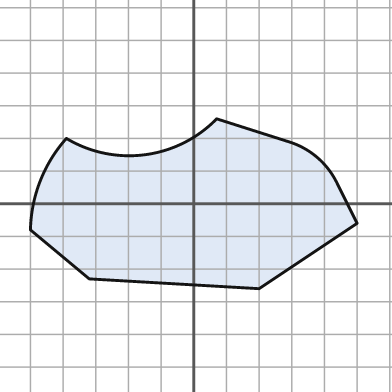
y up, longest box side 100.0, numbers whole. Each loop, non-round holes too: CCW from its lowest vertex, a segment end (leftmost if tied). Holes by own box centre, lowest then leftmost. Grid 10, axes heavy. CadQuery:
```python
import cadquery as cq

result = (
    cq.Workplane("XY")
    .moveTo(20.0, -26.0)
    .lineTo(50.0, -6.0)
    .lineTo(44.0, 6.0)
    .threePointArc((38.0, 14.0), (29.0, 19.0))
    .lineTo(7.0, 26.0)
    .threePointArc((-15.0, 15.0), (-39.0, 20.0))
    .threePointArc((-47.0, 7.0), (-50.0, -8.0))
    .lineTo(-32.0, -23.0)
    .close()
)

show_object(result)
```